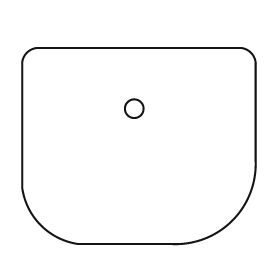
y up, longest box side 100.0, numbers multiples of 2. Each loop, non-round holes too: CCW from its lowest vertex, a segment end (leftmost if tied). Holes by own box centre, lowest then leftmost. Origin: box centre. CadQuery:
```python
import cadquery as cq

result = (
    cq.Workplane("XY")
    .moveTo(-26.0, -42.0)
    .lineTo(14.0, -42.0)
    .threePointArc((40.0, -32.0), (50.0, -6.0))
    .lineTo(50.0, 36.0)
    .threePointArc((48.0, 40.0), (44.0, 42.0))
    .lineTo(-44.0, 42.0)
    .threePointArc((-48.0, 40.0), (-50.0, 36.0))
    .lineTo(-50.0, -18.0)
    .threePointArc((-42.0, -34.0), (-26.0, -42.0))
    .close()
    .moveTo(-2.0, 16.0)
    .circle(4.0)
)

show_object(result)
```